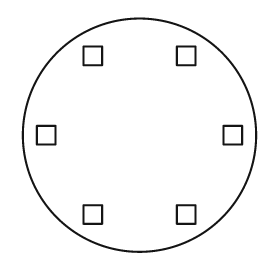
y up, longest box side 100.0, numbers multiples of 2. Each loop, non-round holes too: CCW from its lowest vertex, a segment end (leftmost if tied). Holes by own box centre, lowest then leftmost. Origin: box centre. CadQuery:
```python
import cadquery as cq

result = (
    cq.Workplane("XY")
    .moveTo(0.0, 0.0)
    .circle(50.0)
    .moveTo(-24.0, -38.0)
    .lineTo(-16.0, -38.0)
    .lineTo(-16.0, -30.0)
    .lineTo(-24.0, -30.0)
    .close()
    .moveTo(16.0, -38.0)
    .lineTo(24.0, -38.0)
    .lineTo(24.0, -30.0)
    .lineTo(16.0, -30.0)
    .close()
    .moveTo(-44.0, -4.0)
    .lineTo(-36.0, -4.0)
    .lineTo(-36.0, 4.0)
    .lineTo(-44.0, 4.0)
    .close()
    .moveTo(36.0, -4.0)
    .lineTo(44.0, -4.0)
    .lineTo(44.0, 4.0)
    .lineTo(36.0, 4.0)
    .close()
    .moveTo(-24.0, 30.0)
    .lineTo(-16.0, 30.0)
    .lineTo(-16.0, 38.0)
    .lineTo(-24.0, 38.0)
    .close()
    .moveTo(16.0, 30.0)
    .lineTo(24.0, 30.0)
    .lineTo(24.0, 38.0)
    .lineTo(16.0, 38.0)
    .close()
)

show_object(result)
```